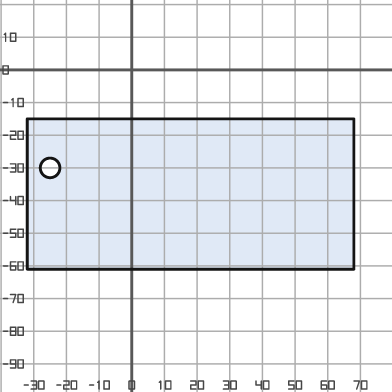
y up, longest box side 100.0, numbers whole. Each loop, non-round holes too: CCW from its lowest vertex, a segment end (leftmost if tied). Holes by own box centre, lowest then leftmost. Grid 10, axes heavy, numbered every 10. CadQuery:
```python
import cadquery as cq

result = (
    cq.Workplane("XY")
    .moveTo(-32.0, -61.0)
    .lineTo(68.0, -61.0)
    .lineTo(68.0, -15.0)
    .lineTo(-32.0, -15.0)
    .close()
    .moveTo(-25.0, -30.0)
    .circle(3.0)
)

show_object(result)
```